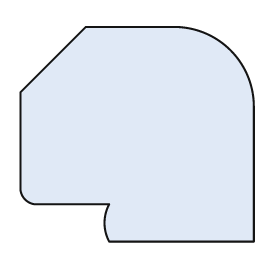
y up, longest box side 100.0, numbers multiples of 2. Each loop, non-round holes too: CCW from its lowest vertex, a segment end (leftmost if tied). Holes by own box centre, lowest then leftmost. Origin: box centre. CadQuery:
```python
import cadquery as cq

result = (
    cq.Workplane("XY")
    .moveTo(-12.0, -46.0)
    .lineTo(50.0, -46.0)
    .lineTo(50.0, 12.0)
    .threePointArc((40.0, 36.0), (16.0, 46.0))
    .lineTo(-22.0, 46.0)
    .lineTo(-50.0, 18.0)
    .lineTo(-50.0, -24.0)
    .threePointArc((-48.0, -28.0), (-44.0, -30.0))
    .lineTo(-12.0, -30.0)
    .threePointArc((-14.0, -38.0), (-12.0, -46.0))
    .close()
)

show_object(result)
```